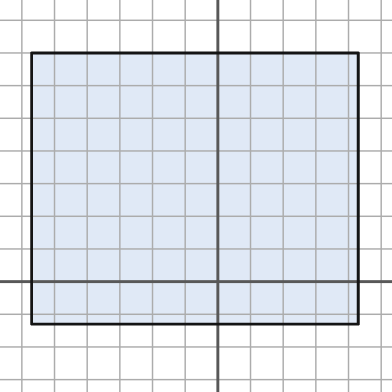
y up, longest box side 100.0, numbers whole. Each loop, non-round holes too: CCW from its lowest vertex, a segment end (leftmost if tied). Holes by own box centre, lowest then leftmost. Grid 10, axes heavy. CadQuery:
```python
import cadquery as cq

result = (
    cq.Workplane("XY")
    .moveTo(-57.0, -13.0)
    .lineTo(43.0, -13.0)
    .lineTo(43.0, 70.0)
    .lineTo(-57.0, 70.0)
    .close()
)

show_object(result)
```